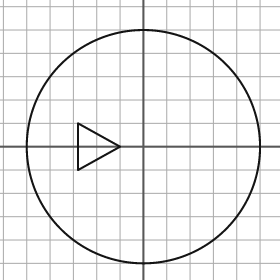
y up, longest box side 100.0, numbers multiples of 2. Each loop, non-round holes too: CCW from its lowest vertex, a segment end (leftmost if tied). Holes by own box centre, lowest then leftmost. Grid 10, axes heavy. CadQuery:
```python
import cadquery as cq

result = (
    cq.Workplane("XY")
    .moveTo(0.0, 0.0)
    .circle(50.0)
    .moveTo(-28.0, -10.0)
    .lineTo(-10.0, 0.0)
    .lineTo(-28.0, 10.0)
    .close()
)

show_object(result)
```